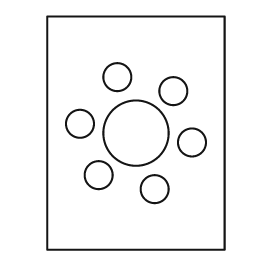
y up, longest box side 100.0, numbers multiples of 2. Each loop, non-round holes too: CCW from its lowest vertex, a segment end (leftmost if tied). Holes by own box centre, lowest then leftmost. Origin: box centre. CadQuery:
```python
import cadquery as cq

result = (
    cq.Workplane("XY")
    .moveTo(-38.0, -50.0)
    .lineTo(38.0, -50.0)
    .lineTo(38.0, 50.0)
    .lineTo(-38.0, 50.0)
    .close()
    .moveTo(8.0, -24.0)
    .circle(6.0)
    .moveTo(-16.0, -18.0)
    .circle(6.0)
    .moveTo(24.0, -4.0)
    .circle(6.0)
    .moveTo(0.0, 0.0)
    .circle(14.0)
    .moveTo(-24.0, 4.0)
    .circle(6.0)
    .moveTo(16.0, 18.0)
    .circle(6.0)
    .moveTo(-8.0, 24.0)
    .circle(6.0)
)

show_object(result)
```